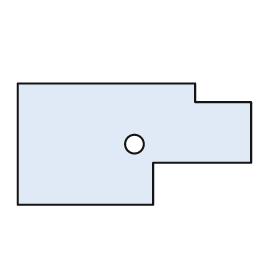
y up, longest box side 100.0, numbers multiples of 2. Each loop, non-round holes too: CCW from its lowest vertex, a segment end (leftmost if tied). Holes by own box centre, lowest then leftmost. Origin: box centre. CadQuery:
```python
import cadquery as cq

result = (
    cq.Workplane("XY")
    .moveTo(-50.0, -26.0)
    .lineTo(8.0, -26.0)
    .lineTo(8.0, -8.0)
    .lineTo(50.0, -8.0)
    .lineTo(50.0, 18.0)
    .lineTo(26.0, 18.0)
    .lineTo(26.0, 26.0)
    .lineTo(-50.0, 26.0)
    .close()
    .moveTo(0.0, 0.0)
    .circle(4.0)
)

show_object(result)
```